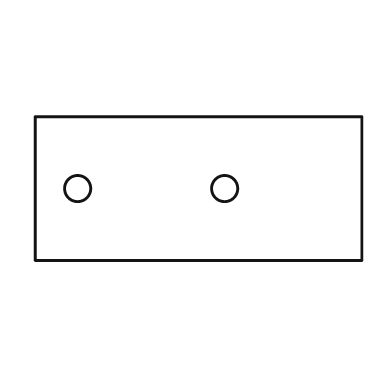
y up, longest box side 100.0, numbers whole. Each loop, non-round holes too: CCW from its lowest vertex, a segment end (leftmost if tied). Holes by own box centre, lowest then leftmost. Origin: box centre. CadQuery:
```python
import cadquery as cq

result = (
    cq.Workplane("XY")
    .moveTo(-50.0, -22.0)
    .lineTo(50.0, -22.0)
    .lineTo(50.0, 22.0)
    .lineTo(-50.0, 22.0)
    .close()
    .moveTo(-37.0, 0.0)
    .circle(4.0)
    .moveTo(8.0, 0.0)
    .circle(4.0)
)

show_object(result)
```